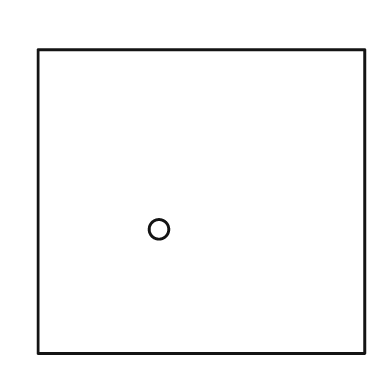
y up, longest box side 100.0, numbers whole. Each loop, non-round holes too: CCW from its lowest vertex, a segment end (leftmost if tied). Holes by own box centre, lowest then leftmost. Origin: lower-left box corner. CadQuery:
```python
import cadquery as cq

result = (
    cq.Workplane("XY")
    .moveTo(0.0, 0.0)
    .lineTo(100.0, 0.0)
    .lineTo(100.0, 93.0)
    .lineTo(0.0, 93.0)
    .close()
    .moveTo(37.0, 38.0)
    .circle(3.0)
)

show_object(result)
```